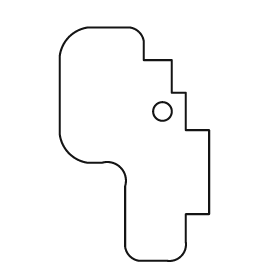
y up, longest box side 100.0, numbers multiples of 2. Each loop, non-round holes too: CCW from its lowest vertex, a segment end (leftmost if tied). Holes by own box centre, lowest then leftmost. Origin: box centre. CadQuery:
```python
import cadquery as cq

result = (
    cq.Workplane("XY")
    .moveTo(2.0, -50.0)
    .lineTo(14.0, -50.0)
    .threePointArc((20.0, -48.0), (22.0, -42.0))
    .lineTo(22.0, -30.0)
    .lineTo(32.0, -30.0)
    .lineTo(32.0, 6.0)
    .lineTo(22.0, 6.0)
    .lineTo(22.0, 22.0)
    .lineTo(16.0, 22.0)
    .lineTo(16.0, 36.0)
    .lineTo(4.0, 36.0)
    .lineTo(4.0, 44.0)
    .threePointArc((2.0, 48.0), (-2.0, 50.0))
    .lineTo(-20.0, 50.0)
    .threePointArc((-28.0, 46.0), (-32.0, 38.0))
    .lineTo(-32.0, 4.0)
    .threePointArc((-28.0, -4.0), (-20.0, -8.0))
    .lineTo(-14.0, -8.0)
    .threePointArc((-6.0, -10.0), (-4.0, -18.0))
    .lineTo(-4.0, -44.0)
    .threePointArc((-2.0, -48.0), (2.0, -50.0))
    .close()
    .moveTo(12.0, 14.0)
    .circle(4.0)
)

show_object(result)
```